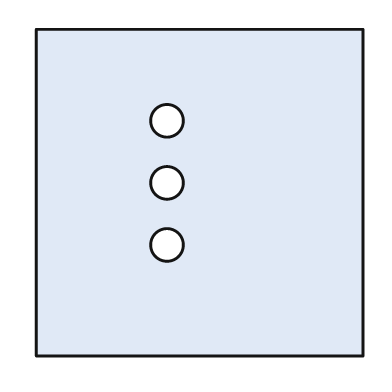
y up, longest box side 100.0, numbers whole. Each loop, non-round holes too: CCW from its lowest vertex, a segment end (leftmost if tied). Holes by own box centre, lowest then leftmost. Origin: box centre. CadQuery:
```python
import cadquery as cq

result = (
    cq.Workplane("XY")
    .moveTo(-50.0, -50.0)
    .lineTo(50.0, -50.0)
    .lineTo(50.0, 50.0)
    .lineTo(-50.0, 50.0)
    .close()
    .moveTo(-10.0, -16.0)
    .circle(5.0)
    .moveTo(-10.0, 3.0)
    .circle(5.0)
    .moveTo(-10.0, 22.0)
    .circle(5.0)
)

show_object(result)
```